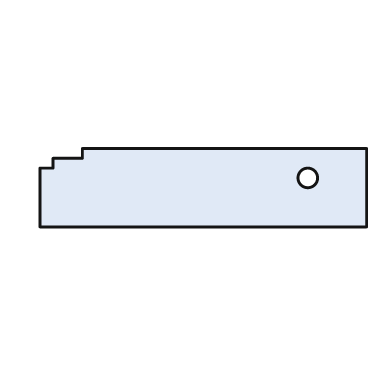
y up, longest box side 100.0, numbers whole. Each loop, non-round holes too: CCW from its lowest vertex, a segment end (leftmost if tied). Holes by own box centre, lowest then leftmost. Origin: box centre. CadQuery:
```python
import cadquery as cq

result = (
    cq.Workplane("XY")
    .moveTo(-50.0, -12.0)
    .lineTo(50.0, -12.0)
    .lineTo(50.0, 12.0)
    .lineTo(-37.0, 12.0)
    .lineTo(-37.0, 9.0)
    .lineTo(-46.0, 9.0)
    .lineTo(-46.0, 6.0)
    .lineTo(-50.0, 6.0)
    .close()
    .moveTo(32.0, 3.0)
    .circle(3.0)
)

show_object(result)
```